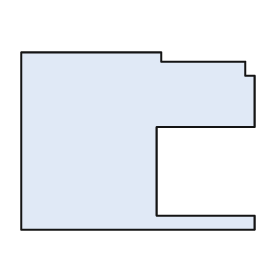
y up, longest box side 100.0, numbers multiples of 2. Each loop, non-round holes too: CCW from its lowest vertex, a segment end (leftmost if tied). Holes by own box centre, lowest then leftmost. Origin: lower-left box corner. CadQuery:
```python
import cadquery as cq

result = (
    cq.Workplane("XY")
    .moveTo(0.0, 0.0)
    .lineTo(100.0, 0.0)
    .lineTo(100.0, 6.0)
    .lineTo(58.0, 6.0)
    .lineTo(58.0, 44.0)
    .lineTo(100.0, 44.0)
    .lineTo(100.0, 66.0)
    .lineTo(96.0, 66.0)
    .lineTo(96.0, 72.0)
    .lineTo(60.0, 72.0)
    .lineTo(60.0, 76.0)
    .lineTo(0.0, 76.0)
    .close()
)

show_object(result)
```